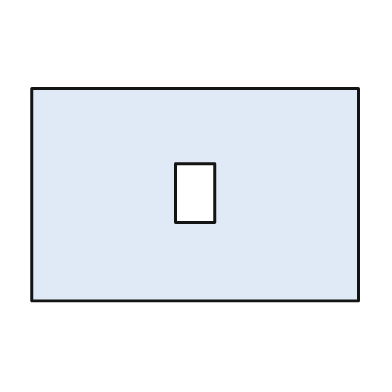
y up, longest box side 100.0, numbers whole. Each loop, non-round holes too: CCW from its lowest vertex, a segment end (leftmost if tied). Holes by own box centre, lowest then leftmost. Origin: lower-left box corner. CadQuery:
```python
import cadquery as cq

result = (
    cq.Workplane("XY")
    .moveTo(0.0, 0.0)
    .lineTo(100.0, 0.0)
    .lineTo(100.0, 65.0)
    .lineTo(0.0, 65.0)
    .close()
    .moveTo(44.0, 24.0)
    .lineTo(56.0, 24.0)
    .lineTo(56.0, 42.0)
    .lineTo(44.0, 42.0)
    .close()
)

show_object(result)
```